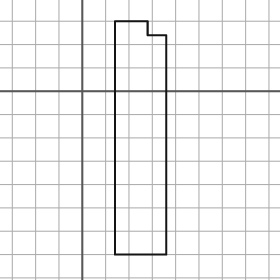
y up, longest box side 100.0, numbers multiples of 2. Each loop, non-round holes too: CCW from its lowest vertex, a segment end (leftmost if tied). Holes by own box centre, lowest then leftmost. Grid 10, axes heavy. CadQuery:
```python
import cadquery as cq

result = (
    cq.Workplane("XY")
    .moveTo(14.0, -70.0)
    .lineTo(36.0, -70.0)
    .lineTo(36.0, 24.0)
    .lineTo(28.0, 24.0)
    .lineTo(28.0, 30.0)
    .lineTo(14.0, 30.0)
    .close()
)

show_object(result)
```